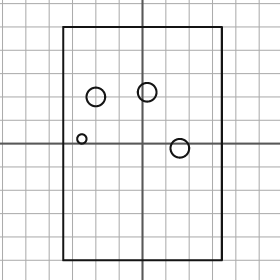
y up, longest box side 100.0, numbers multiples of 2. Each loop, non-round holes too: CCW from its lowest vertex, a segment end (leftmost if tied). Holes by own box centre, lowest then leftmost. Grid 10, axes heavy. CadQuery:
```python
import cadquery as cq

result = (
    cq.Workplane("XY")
    .moveTo(-34.0, -50.0)
    .lineTo(34.0, -50.0)
    .lineTo(34.0, 50.0)
    .lineTo(-34.0, 50.0)
    .close()
    .moveTo(16.0, -2.0)
    .circle(4.0)
    .moveTo(-26.0, 2.0)
    .circle(2.0)
    .moveTo(-20.0, 20.0)
    .circle(4.0)
    .moveTo(2.0, 22.0)
    .circle(4.0)
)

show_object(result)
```